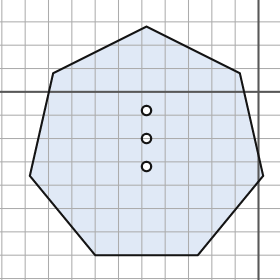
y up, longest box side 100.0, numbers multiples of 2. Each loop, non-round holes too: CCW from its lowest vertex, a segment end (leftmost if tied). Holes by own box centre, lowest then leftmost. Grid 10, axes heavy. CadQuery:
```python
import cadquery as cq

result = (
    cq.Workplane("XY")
    .moveTo(-70.0, -70.0)
    .lineTo(-26.0, -70.0)
    .lineTo(2.0, -36.0)
    .lineTo(-8.0, 8.0)
    .lineTo(-48.0, 28.0)
    .lineTo(-88.0, 8.0)
    .lineTo(-98.0, -36.0)
    .close()
    .moveTo(-48.0, -32.0)
    .circle(2.0)
    .moveTo(-48.0, -20.0)
    .circle(2.0)
    .moveTo(-48.0, -8.0)
    .circle(2.0)
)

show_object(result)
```